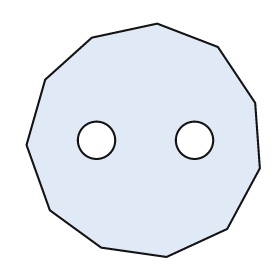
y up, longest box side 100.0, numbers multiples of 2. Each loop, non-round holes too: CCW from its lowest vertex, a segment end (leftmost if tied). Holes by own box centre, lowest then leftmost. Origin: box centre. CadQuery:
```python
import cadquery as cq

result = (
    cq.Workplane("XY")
    .moveTo(10.0, -50.0)
    .lineTo(36.0, -38.0)
    .lineTo(50.0, -12.0)
    .lineTo(48.0, 16.0)
    .lineTo(32.0, 40.0)
    .lineTo(6.0, 50.0)
    .lineTo(-22.0, 44.0)
    .lineTo(-42.0, 26.0)
    .lineTo(-50.0, -2.0)
    .lineTo(-40.0, -30.0)
    .lineTo(-18.0, -46.0)
    .close()
    .moveTo(-20.0, 0.0)
    .circle(8.0)
    .moveTo(22.0, 0.0)
    .circle(8.0)
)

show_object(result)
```